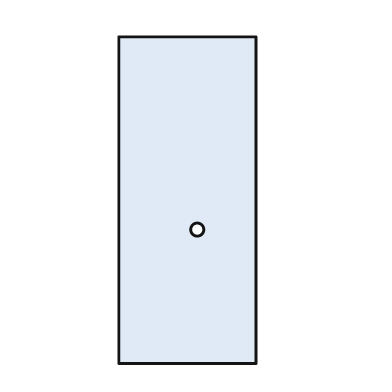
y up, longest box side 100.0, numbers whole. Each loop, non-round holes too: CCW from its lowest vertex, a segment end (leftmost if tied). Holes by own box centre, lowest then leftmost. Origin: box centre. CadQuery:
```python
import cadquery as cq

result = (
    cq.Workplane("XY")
    .moveTo(-21.0, -50.0)
    .lineTo(21.0, -50.0)
    .lineTo(21.0, 50.0)
    .lineTo(-21.0, 50.0)
    .close()
    .moveTo(3.0, -9.0)
    .circle(2.0)
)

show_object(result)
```